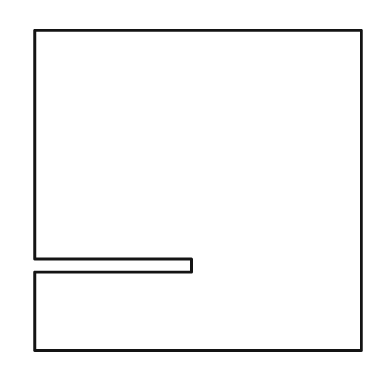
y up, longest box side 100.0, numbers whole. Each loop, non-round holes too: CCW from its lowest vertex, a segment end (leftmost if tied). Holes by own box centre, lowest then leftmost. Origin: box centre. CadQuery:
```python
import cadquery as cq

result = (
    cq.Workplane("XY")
    .moveTo(-50.0, -49.0)
    .lineTo(50.0, -49.0)
    .lineTo(50.0, 49.0)
    .lineTo(-50.0, 49.0)
    .lineTo(-50.0, -21.0)
    .lineTo(-2.0, -21.0)
    .lineTo(-2.0, -25.0)
    .lineTo(-50.0, -25.0)
    .close()
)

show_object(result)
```